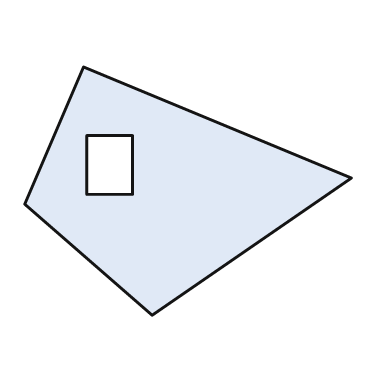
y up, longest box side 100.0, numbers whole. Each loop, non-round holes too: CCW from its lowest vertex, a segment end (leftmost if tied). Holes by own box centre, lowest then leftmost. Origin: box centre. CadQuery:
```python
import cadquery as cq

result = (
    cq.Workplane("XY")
    .moveTo(-11.0, -38.0)
    .lineTo(50.0, 4.0)
    .lineTo(-32.0, 38.0)
    .lineTo(-50.0, -4.0)
    .close()
    .moveTo(-31.0, -1.0)
    .lineTo(-17.0, -1.0)
    .lineTo(-17.0, 17.0)
    .lineTo(-31.0, 17.0)
    .close()
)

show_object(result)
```